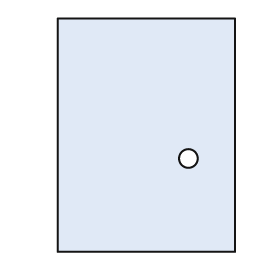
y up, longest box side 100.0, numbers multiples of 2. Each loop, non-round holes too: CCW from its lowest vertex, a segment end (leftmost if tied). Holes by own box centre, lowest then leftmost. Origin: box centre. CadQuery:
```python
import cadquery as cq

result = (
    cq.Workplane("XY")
    .moveTo(-38.0, -50.0)
    .lineTo(38.0, -50.0)
    .lineTo(38.0, 50.0)
    .lineTo(-38.0, 50.0)
    .close()
    .moveTo(18.0, -10.0)
    .circle(4.0)
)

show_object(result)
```